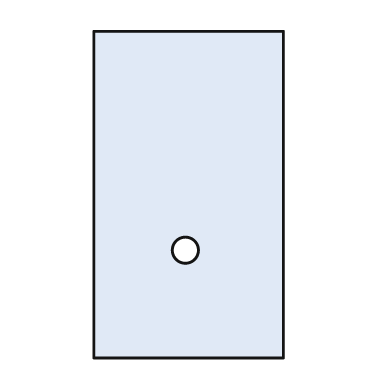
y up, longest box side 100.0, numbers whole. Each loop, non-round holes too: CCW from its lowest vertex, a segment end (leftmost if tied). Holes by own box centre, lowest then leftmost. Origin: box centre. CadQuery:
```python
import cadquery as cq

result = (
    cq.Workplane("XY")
    .moveTo(-29.0, -50.0)
    .lineTo(29.0, -50.0)
    .lineTo(29.0, 50.0)
    .lineTo(-29.0, 50.0)
    .close()
    .moveTo(-1.0, -17.0)
    .circle(4.0)
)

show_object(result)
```